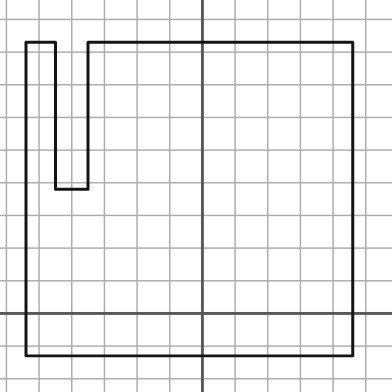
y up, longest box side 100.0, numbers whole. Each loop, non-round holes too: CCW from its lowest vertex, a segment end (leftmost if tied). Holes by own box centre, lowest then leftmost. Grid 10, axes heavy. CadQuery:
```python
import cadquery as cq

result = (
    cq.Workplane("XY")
    .moveTo(-54.0, -13.0)
    .lineTo(46.0, -13.0)
    .lineTo(46.0, 83.0)
    .lineTo(-35.0, 83.0)
    .lineTo(-35.0, 38.0)
    .lineTo(-45.0, 38.0)
    .lineTo(-45.0, 83.0)
    .lineTo(-54.0, 83.0)
    .close()
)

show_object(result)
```